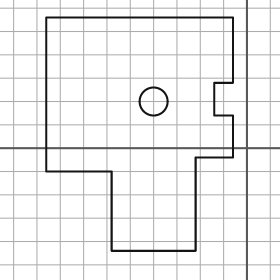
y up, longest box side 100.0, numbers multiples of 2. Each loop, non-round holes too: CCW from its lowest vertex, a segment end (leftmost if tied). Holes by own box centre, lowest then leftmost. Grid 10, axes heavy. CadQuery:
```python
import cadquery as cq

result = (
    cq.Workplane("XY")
    .moveTo(-58.0, -44.0)
    .lineTo(-22.0, -44.0)
    .lineTo(-22.0, -4.0)
    .lineTo(-6.0, -4.0)
    .lineTo(-6.0, 14.0)
    .lineTo(-14.0, 14.0)
    .lineTo(-14.0, 28.0)
    .lineTo(-6.0, 28.0)
    .lineTo(-6.0, 56.0)
    .lineTo(-86.0, 56.0)
    .lineTo(-86.0, -10.0)
    .lineTo(-58.0, -10.0)
    .close()
    .moveTo(-40.0, 20.0)
    .circle(6.0)
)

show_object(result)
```